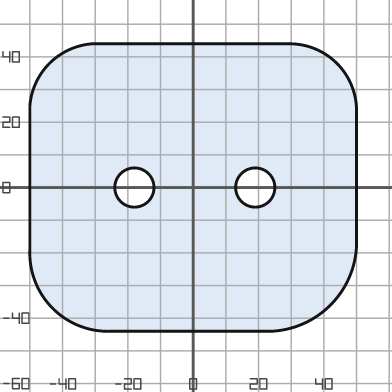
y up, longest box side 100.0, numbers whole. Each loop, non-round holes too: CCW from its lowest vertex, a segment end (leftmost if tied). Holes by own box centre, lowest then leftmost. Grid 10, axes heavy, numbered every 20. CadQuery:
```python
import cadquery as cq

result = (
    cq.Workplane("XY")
    .moveTo(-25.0, -44.0)
    .lineTo(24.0, -44.0)
    .threePointArc((42.0, -36.0), (50.0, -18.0))
    .lineTo(50.0, 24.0)
    .threePointArc((44.0, 38.0), (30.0, 44.0))
    .lineTo(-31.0, 44.0)
    .threePointArc((-44.0, 38.0), (-50.0, 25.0))
    .lineTo(-50.0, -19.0)
    .threePointArc((-43.0, -37.0), (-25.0, -44.0))
    .close()
    .moveTo(-18.0, 0.0)
    .circle(6.0)
    .moveTo(19.0, 0.0)
    .circle(6.0)
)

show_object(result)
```